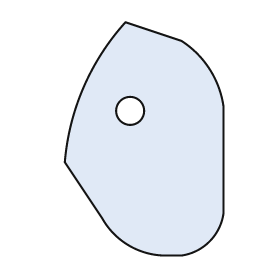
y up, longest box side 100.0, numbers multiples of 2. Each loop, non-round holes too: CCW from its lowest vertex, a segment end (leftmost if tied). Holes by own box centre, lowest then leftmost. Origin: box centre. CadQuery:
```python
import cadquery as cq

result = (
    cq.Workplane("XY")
    .moveTo(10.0, -50.0)
    .lineTo(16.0, -50.0)
    .threePointArc((28.0, -44.0), (34.0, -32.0))
    .lineTo(34.0, 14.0)
    .threePointArc((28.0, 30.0), (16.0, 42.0))
    .lineTo(-8.0, 50.0)
    .threePointArc((-26.0, 22.0), (-34.0, -10.0))
    .lineTo(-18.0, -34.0)
    .threePointArc((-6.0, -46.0), (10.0, -50.0))
    .close()
    .moveTo(-6.0, 12.0)
    .circle(6.0)
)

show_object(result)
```